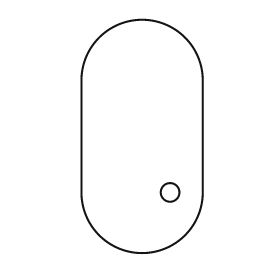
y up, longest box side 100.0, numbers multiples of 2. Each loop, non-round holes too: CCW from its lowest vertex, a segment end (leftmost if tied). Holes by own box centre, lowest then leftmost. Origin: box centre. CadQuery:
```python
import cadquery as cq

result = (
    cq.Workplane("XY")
    .moveTo(-26.0, -24.0)
    .threePointArc((0.0, -50.0), (26.0, -24.0))
    .lineTo(26.0, 24.0)
    .threePointArc((0.0, 50.0), (-26.0, 24.0))
    .close()
    .moveTo(12.0, -24.0)
    .circle(4.0)
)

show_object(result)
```